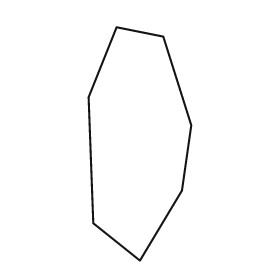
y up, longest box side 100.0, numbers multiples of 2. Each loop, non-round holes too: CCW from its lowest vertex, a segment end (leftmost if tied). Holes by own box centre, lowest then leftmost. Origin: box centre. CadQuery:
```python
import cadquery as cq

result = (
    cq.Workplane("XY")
    .moveTo(0.0, -50.0)
    .lineTo(18.0, -20.0)
    .lineTo(22.0, 8.0)
    .lineTo(10.0, 46.0)
    .lineTo(-10.0, 50.0)
    .lineTo(-22.0, 20.0)
    .lineTo(-20.0, -34.0)
    .close()
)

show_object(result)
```